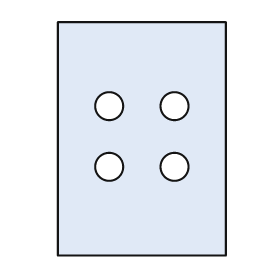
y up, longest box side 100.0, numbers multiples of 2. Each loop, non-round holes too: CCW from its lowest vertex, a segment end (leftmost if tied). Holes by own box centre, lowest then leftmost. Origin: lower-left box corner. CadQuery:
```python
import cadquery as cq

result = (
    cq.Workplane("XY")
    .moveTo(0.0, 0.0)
    .lineTo(72.0, 0.0)
    .lineTo(72.0, 100.0)
    .lineTo(0.0, 100.0)
    .close()
    .moveTo(22.0, 38.0)
    .circle(6.0)
    .moveTo(50.0, 38.0)
    .circle(6.0)
    .moveTo(22.0, 64.0)
    .circle(6.0)
    .moveTo(50.0, 64.0)
    .circle(6.0)
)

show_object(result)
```